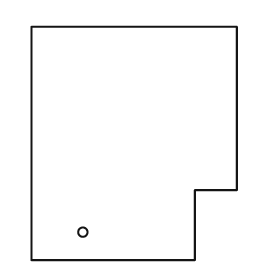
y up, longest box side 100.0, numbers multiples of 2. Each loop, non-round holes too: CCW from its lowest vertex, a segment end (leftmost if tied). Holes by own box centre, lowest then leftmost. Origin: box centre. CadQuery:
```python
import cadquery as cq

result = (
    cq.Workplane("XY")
    .moveTo(-44.0, -50.0)
    .lineTo(26.0, -50.0)
    .lineTo(26.0, -20.0)
    .lineTo(44.0, -20.0)
    .lineTo(44.0, 50.0)
    .lineTo(-44.0, 50.0)
    .close()
    .moveTo(-22.0, -38.0)
    .circle(2.0)
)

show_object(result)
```